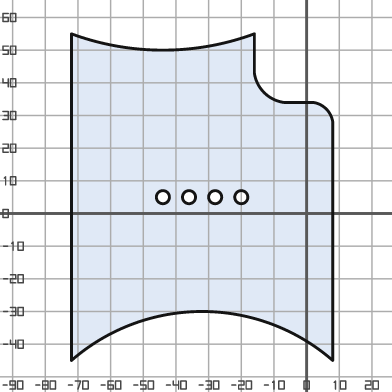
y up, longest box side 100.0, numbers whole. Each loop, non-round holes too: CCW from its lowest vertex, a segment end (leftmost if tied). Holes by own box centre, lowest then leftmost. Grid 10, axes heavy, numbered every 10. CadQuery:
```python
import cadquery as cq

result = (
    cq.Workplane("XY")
    .moveTo(-72.0, -45.0)
    .threePointArc((-32.0, -30.0), (8.0, -45.0))
    .lineTo(8.0, 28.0)
    .threePointArc((6.0, 32.0), (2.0, 34.0))
    .lineTo(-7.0, 34.0)
    .threePointArc((-13.0, 37.0), (-16.0, 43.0))
    .lineTo(-16.0, 55.0)
    .threePointArc((-44.0, 50.0), (-72.0, 55.0))
    .close()
    .moveTo(-44.0, 5.0)
    .circle(2.0)
    .moveTo(-36.0, 5.0)
    .circle(2.0)
    .moveTo(-28.0, 5.0)
    .circle(2.0)
    .moveTo(-20.0, 5.0)
    .circle(2.0)
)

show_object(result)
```